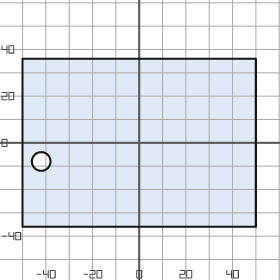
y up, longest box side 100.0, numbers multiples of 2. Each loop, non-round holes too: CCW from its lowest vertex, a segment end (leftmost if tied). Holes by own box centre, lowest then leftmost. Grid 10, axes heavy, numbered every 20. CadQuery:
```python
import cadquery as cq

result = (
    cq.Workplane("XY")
    .moveTo(-50.0, -36.0)
    .lineTo(50.0, -36.0)
    .lineTo(50.0, 36.0)
    .lineTo(-50.0, 36.0)
    .close()
    .moveTo(-42.0, -8.0)
    .circle(4.0)
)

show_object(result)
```